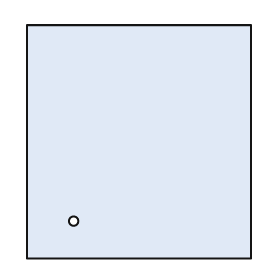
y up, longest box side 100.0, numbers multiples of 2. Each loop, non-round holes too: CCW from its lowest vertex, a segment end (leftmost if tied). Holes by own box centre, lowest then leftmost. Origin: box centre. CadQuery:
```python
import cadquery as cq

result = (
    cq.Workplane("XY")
    .moveTo(-48.0, -50.0)
    .lineTo(48.0, -50.0)
    .lineTo(48.0, 50.0)
    .lineTo(-48.0, 50.0)
    .close()
    .moveTo(-28.0, -34.0)
    .circle(2.0)
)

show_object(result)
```